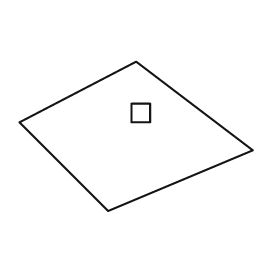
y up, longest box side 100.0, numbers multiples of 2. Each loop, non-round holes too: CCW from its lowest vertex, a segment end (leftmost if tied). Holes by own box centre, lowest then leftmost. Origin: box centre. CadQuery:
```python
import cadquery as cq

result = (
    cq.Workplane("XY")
    .moveTo(-12.0, -32.0)
    .lineTo(50.0, -6.0)
    .lineTo(0.0, 32.0)
    .lineTo(-50.0, 6.0)
    .close()
    .moveTo(-2.0, 6.0)
    .lineTo(6.0, 6.0)
    .lineTo(6.0, 14.0)
    .lineTo(-2.0, 14.0)
    .close()
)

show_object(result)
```